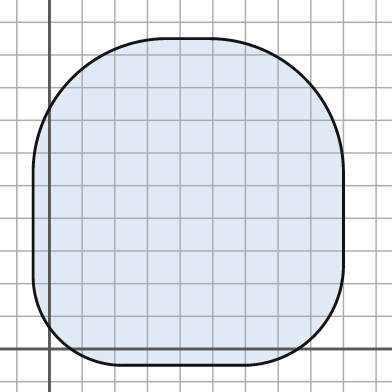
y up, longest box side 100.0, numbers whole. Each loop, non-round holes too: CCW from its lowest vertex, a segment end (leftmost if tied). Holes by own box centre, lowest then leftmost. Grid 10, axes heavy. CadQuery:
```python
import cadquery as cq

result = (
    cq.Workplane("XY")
    .moveTo(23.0, -5.0)
    .lineTo(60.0, -5.0)
    .threePointArc((81.0, 4.0), (90.0, 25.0))
    .lineTo(90.0, 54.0)
    .threePointArc((78.0, 83.0), (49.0, 95.0))
    .lineTo(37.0, 95.0)
    .threePointArc((7.0, 83.0), (-5.0, 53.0))
    .lineTo(-5.0, 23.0)
    .threePointArc((3.0, 3.0), (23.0, -5.0))
    .close()
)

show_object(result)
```